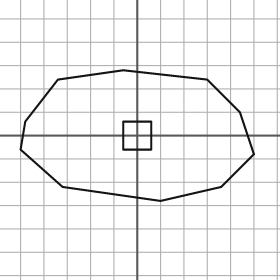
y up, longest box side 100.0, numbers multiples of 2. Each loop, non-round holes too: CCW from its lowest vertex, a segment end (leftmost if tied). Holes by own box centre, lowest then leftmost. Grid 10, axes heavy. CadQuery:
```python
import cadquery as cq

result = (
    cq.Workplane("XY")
    .moveTo(10.0, -28.0)
    .lineTo(36.0, -22.0)
    .lineTo(50.0, -8.0)
    .lineTo(44.0, 10.0)
    .lineTo(30.0, 24.0)
    .lineTo(-6.0, 28.0)
    .lineTo(-34.0, 24.0)
    .lineTo(-48.0, 6.0)
    .lineTo(-50.0, -6.0)
    .lineTo(-32.0, -22.0)
    .close()
    .moveTo(-6.0, -6.0)
    .lineTo(6.0, -6.0)
    .lineTo(6.0, 6.0)
    .lineTo(-6.0, 6.0)
    .close()
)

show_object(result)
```